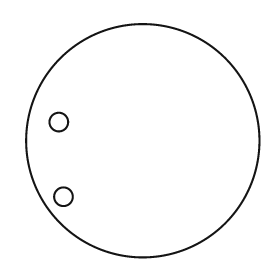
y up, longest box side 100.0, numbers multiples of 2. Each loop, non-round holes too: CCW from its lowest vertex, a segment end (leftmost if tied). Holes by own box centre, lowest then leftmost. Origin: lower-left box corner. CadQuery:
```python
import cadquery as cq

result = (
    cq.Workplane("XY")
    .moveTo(50.0, 50.0)
    .circle(50.0)
    .moveTo(16.0, 26.0)
    .circle(4.0)
    .moveTo(14.0, 58.0)
    .circle(4.0)
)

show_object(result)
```